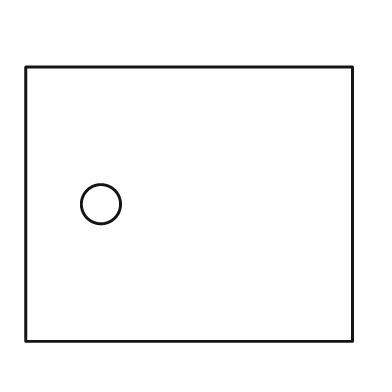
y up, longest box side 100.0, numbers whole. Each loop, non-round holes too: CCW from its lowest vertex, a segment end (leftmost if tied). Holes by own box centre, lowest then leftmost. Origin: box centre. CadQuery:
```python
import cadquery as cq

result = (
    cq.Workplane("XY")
    .moveTo(-50.0, -42.0)
    .lineTo(50.0, -42.0)
    .lineTo(50.0, 42.0)
    .lineTo(-50.0, 42.0)
    .close()
    .moveTo(-27.0, 0.0)
    .circle(6.0)
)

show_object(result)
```